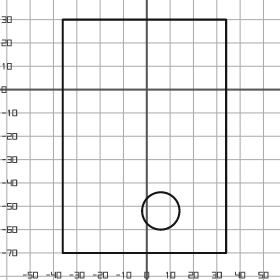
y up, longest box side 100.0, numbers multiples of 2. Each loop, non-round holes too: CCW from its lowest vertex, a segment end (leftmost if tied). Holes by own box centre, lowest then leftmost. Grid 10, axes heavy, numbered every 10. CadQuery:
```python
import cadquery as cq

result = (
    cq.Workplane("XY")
    .moveTo(-36.0, -70.0)
    .lineTo(34.0, -70.0)
    .lineTo(34.0, 30.0)
    .lineTo(-36.0, 30.0)
    .close()
    .moveTo(6.0, -52.0)
    .circle(8.0)
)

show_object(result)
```